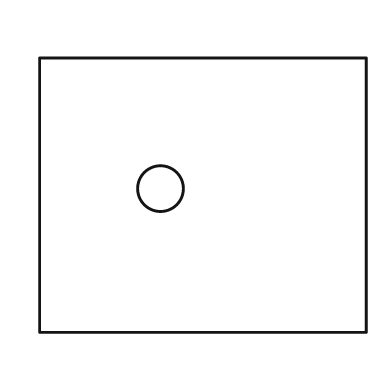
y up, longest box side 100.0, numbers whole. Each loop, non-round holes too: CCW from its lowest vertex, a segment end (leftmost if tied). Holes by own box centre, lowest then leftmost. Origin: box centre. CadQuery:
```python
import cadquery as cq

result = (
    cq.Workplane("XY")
    .moveTo(-50.0, -42.0)
    .lineTo(50.0, -42.0)
    .lineTo(50.0, 42.0)
    .lineTo(-50.0, 42.0)
    .close()
    .moveTo(-13.0, 2.0)
    .circle(7.0)
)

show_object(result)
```